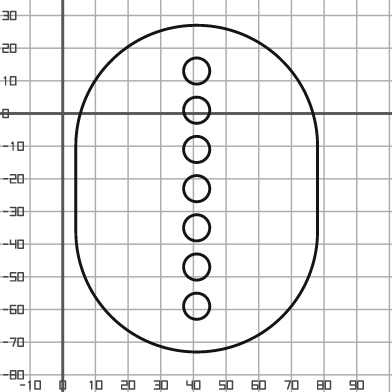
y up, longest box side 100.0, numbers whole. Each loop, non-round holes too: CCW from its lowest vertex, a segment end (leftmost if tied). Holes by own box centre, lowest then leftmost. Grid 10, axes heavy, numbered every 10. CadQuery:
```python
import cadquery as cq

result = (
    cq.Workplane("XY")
    .moveTo(4.0, -36.0)
    .threePointArc((41.0, -73.0), (78.0, -36.0))
    .lineTo(78.0, -10.0)
    .threePointArc((41.0, 27.0), (4.0, -10.0))
    .close()
    .moveTo(41.0, -59.0)
    .circle(4.0)
    .moveTo(41.0, -47.0)
    .circle(4.0)
    .moveTo(41.0, -35.0)
    .circle(4.0)
    .moveTo(41.0, -23.0)
    .circle(4.0)
    .moveTo(41.0, -11.0)
    .circle(4.0)
    .moveTo(41.0, 1.0)
    .circle(4.0)
    .moveTo(41.0, 13.0)
    .circle(4.0)
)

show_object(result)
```